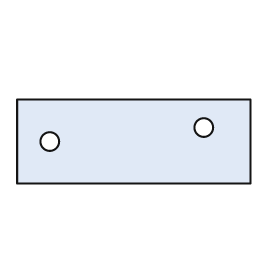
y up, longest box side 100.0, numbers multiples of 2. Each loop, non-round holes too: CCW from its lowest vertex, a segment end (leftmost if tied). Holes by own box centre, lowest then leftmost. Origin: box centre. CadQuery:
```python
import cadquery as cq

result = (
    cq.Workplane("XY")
    .moveTo(-50.0, -18.0)
    .lineTo(50.0, -18.0)
    .lineTo(50.0, 18.0)
    .lineTo(-50.0, 18.0)
    .close()
    .moveTo(-36.0, 0.0)
    .circle(4.0)
    .moveTo(30.0, 6.0)
    .circle(4.0)
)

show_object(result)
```